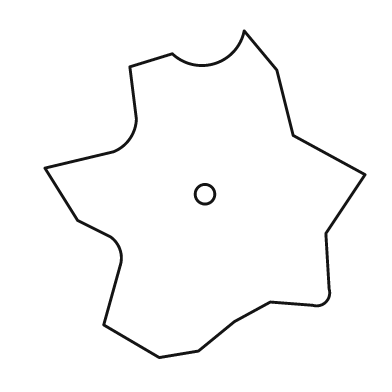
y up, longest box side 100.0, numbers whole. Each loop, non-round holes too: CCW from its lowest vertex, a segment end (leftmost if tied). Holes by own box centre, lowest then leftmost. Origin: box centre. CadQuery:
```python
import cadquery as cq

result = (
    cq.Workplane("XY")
    .moveTo(-14.0, -50.0)
    .lineTo(-2.0, -48.0)
    .lineTo(9.0, -39.0)
    .lineTo(20.0, -33.0)
    .lineTo(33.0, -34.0)
    .threePointArc((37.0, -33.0), (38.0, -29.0))
    .lineTo(37.0, -12.0)
    .lineTo(49.0, 6.0)
    .lineTo(27.0, 18.0)
    .lineTo(22.0, 38.0)
    .lineTo(12.0, 50.0)
    .threePointArc((3.0, 40.0), (-10.0, 43.0))
    .lineTo(-23.0, 39.0)
    .lineTo(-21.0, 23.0)
    .threePointArc((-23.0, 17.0), (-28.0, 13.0))
    .lineTo(-49.0, 8.0)
    .lineTo(-39.0, -8.0)
    .lineTo(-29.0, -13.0)
    .threePointArc((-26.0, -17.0), (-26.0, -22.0))
    .lineTo(-31.0, -40.0)
    .close()
    .moveTo(0.0, 0.0)
    .circle(3.0)
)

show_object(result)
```